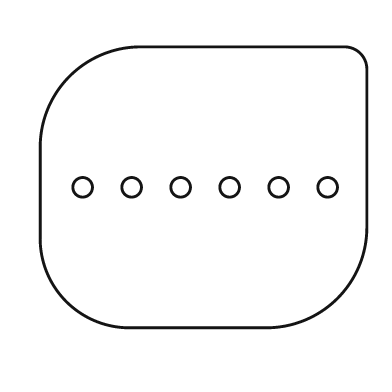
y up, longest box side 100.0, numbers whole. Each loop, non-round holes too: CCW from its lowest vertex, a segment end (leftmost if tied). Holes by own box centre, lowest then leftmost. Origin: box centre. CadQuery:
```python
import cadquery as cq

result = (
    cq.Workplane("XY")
    .moveTo(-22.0, -43.0)
    .lineTo(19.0, -43.0)
    .threePointArc((41.0, -34.0), (50.0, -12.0))
    .lineTo(50.0, 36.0)
    .threePointArc((48.0, 41.0), (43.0, 43.0))
    .lineTo(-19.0, 43.0)
    .threePointArc((-41.0, 34.0), (-50.0, 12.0))
    .lineTo(-50.0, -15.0)
    .threePointArc((-42.0, -35.0), (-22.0, -43.0))
    .close()
    .moveTo(-37.0, 0.0)
    .circle(3.0)
    .moveTo(-22.0, 0.0)
    .circle(3.0)
    .moveTo(-7.0, 0.0)
    .circle(3.0)
    .moveTo(8.0, 0.0)
    .circle(3.0)
    .moveTo(23.0, 0.0)
    .circle(3.0)
    .moveTo(38.0, 0.0)
    .circle(3.0)
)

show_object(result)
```